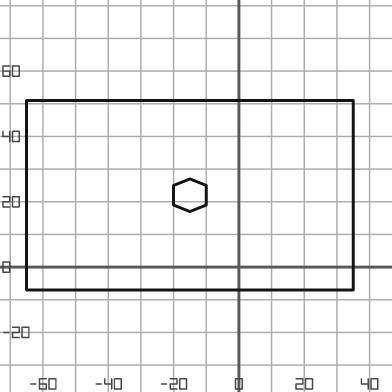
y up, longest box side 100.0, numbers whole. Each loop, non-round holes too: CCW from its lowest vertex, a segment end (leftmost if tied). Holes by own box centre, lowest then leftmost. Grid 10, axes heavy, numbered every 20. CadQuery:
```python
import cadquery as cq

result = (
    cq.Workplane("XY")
    .moveTo(-65.0, -7.0)
    .lineTo(35.0, -7.0)
    .lineTo(35.0, 51.0)
    .lineTo(-65.0, 51.0)
    .close()
    .moveTo(-15.0, 17.0)
    .lineTo(-10.0, 19.0)
    .lineTo(-10.0, 25.0)
    .lineTo(-15.0, 27.0)
    .lineTo(-20.0, 25.0)
    .lineTo(-20.0, 19.0)
    .close()
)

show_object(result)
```